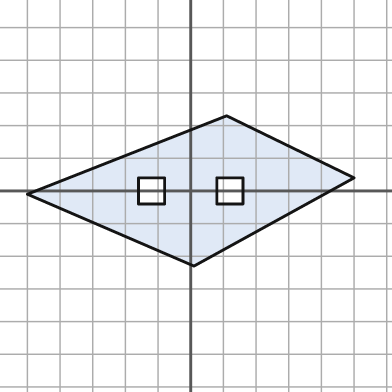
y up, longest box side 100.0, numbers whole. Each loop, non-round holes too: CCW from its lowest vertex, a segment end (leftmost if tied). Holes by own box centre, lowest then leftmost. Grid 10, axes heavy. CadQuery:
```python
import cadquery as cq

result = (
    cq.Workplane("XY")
    .moveTo(1.0, -23.0)
    .lineTo(50.0, 4.0)
    .lineTo(11.0, 23.0)
    .lineTo(-50.0, -1.0)
    .close()
    .moveTo(-16.0, -4.0)
    .lineTo(-8.0, -4.0)
    .lineTo(-8.0, 4.0)
    .lineTo(-16.0, 4.0)
    .close()
    .moveTo(8.0, -4.0)
    .lineTo(16.0, -4.0)
    .lineTo(16.0, 4.0)
    .lineTo(8.0, 4.0)
    .close()
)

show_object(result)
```